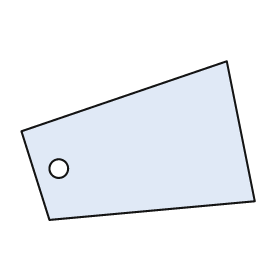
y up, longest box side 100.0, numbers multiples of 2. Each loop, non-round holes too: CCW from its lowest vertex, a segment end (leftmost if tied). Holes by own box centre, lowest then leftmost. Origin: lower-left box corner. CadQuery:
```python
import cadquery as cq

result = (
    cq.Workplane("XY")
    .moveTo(12.0, 0.0)
    .lineTo(100.0, 8.0)
    .lineTo(88.0, 68.0)
    .lineTo(0.0, 38.0)
    .close()
    .moveTo(16.0, 22.0)
    .circle(4.0)
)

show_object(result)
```